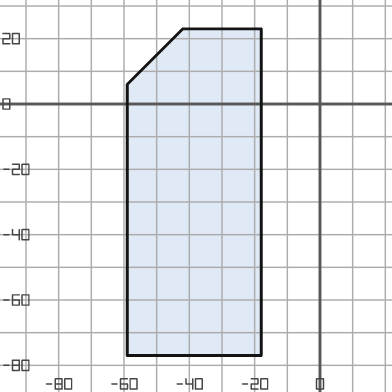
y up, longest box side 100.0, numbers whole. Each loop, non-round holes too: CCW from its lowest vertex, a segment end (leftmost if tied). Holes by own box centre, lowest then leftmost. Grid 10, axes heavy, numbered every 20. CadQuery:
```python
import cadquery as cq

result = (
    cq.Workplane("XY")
    .moveTo(-59.0, -77.0)
    .lineTo(-18.0, -77.0)
    .lineTo(-18.0, 23.0)
    .lineTo(-42.0, 23.0)
    .lineTo(-59.0, 6.0)
    .close()
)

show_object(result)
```